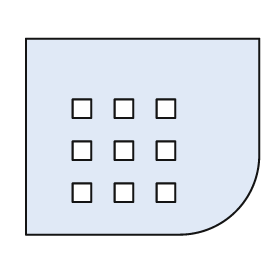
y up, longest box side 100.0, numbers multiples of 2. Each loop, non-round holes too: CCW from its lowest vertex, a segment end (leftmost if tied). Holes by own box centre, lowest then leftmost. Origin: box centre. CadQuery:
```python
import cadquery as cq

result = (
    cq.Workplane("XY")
    .moveTo(-50.0, -42.0)
    .lineTo(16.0, -42.0)
    .threePointArc((40.0, -32.0), (50.0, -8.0))
    .lineTo(50.0, 42.0)
    .lineTo(-50.0, 42.0)
    .close()
    .moveTo(-30.0, -28.0)
    .lineTo(-22.0, -28.0)
    .lineTo(-22.0, -20.0)
    .lineTo(-30.0, -20.0)
    .close()
    .moveTo(-12.0, -28.0)
    .lineTo(-4.0, -28.0)
    .lineTo(-4.0, -20.0)
    .lineTo(-12.0, -20.0)
    .close()
    .moveTo(6.0, -28.0)
    .lineTo(14.0, -28.0)
    .lineTo(14.0, -20.0)
    .lineTo(6.0, -20.0)
    .close()
    .moveTo(-30.0, -10.0)
    .lineTo(-22.0, -10.0)
    .lineTo(-22.0, -2.0)
    .lineTo(-30.0, -2.0)
    .close()
    .moveTo(-12.0, -10.0)
    .lineTo(-4.0, -10.0)
    .lineTo(-4.0, -2.0)
    .lineTo(-12.0, -2.0)
    .close()
    .moveTo(6.0, -10.0)
    .lineTo(14.0, -10.0)
    .lineTo(14.0, -2.0)
    .lineTo(6.0, -2.0)
    .close()
    .moveTo(-30.0, 8.0)
    .lineTo(-22.0, 8.0)
    .lineTo(-22.0, 16.0)
    .lineTo(-30.0, 16.0)
    .close()
    .moveTo(-12.0, 8.0)
    .lineTo(-4.0, 8.0)
    .lineTo(-4.0, 16.0)
    .lineTo(-12.0, 16.0)
    .close()
    .moveTo(6.0, 8.0)
    .lineTo(14.0, 8.0)
    .lineTo(14.0, 16.0)
    .lineTo(6.0, 16.0)
    .close()
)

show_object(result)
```